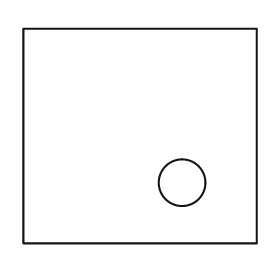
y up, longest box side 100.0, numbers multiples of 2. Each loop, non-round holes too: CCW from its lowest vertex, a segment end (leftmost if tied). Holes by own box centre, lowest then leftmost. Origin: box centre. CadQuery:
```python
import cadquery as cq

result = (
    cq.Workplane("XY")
    .moveTo(-50.0, -46.0)
    .lineTo(50.0, -46.0)
    .lineTo(50.0, 46.0)
    .lineTo(-50.0, 46.0)
    .close()
    .moveTo(18.0, -20.0)
    .circle(10.0)
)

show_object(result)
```